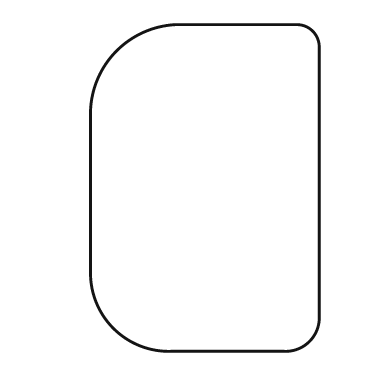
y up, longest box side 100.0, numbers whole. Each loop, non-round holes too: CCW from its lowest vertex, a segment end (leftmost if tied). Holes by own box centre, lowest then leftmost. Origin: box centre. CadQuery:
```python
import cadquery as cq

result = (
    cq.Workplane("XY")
    .moveTo(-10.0, -50.0)
    .lineTo(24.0, -50.0)
    .threePointArc((32.0, -47.0), (35.0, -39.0))
    .lineTo(35.0, 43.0)
    .threePointArc((33.0, 48.0), (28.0, 50.0))
    .lineTo(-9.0, 50.0)
    .threePointArc((-27.0, 42.0), (-35.0, 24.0))
    .lineTo(-35.0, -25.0)
    .threePointArc((-28.0, -43.0), (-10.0, -50.0))
    .close()
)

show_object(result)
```